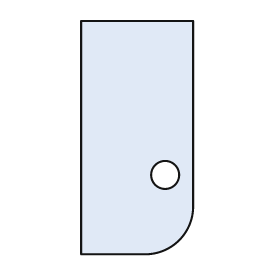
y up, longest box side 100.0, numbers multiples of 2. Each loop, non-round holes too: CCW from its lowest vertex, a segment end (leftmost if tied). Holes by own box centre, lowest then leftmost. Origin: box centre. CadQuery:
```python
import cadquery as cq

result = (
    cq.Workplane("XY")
    .moveTo(-24.0, -50.0)
    .lineTo(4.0, -50.0)
    .threePointArc((18.0, -44.0), (24.0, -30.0))
    .lineTo(24.0, 50.0)
    .lineTo(-24.0, 50.0)
    .close()
    .moveTo(12.0, -16.0)
    .circle(6.0)
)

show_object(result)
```